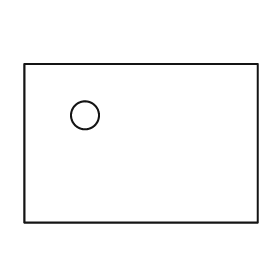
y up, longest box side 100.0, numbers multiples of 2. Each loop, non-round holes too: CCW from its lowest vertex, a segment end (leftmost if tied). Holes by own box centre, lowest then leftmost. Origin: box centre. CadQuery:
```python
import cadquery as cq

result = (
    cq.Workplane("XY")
    .moveTo(-50.0, -34.0)
    .lineTo(50.0, -34.0)
    .lineTo(50.0, 34.0)
    .lineTo(-50.0, 34.0)
    .close()
    .moveTo(-24.0, 12.0)
    .circle(6.0)
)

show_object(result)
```